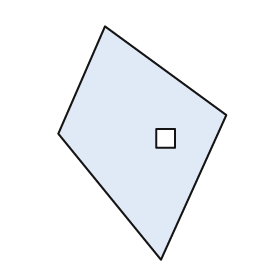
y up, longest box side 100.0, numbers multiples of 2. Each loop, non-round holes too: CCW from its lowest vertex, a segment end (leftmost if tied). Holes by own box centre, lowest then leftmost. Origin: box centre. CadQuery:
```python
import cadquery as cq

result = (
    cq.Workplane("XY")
    .moveTo(8.0, -50.0)
    .lineTo(36.0, 12.0)
    .lineTo(-16.0, 50.0)
    .lineTo(-36.0, 4.0)
    .close()
    .moveTo(6.0, -2.0)
    .lineTo(14.0, -2.0)
    .lineTo(14.0, 6.0)
    .lineTo(6.0, 6.0)
    .close()
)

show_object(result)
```